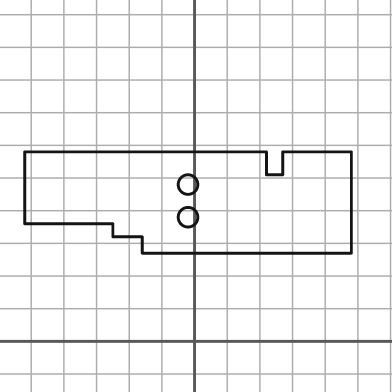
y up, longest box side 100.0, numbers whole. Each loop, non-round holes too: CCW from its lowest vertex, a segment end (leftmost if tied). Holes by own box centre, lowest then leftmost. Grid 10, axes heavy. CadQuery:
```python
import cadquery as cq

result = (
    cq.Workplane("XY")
    .moveTo(-16.0, 27.0)
    .lineTo(48.0, 27.0)
    .lineTo(48.0, 58.0)
    .lineTo(27.0, 58.0)
    .lineTo(27.0, 51.0)
    .lineTo(22.0, 51.0)
    .lineTo(22.0, 58.0)
    .lineTo(-52.0, 58.0)
    .lineTo(-52.0, 36.0)
    .lineTo(-25.0, 36.0)
    .lineTo(-25.0, 32.0)
    .lineTo(-16.0, 32.0)
    .close()
    .moveTo(-2.0, 38.0)
    .circle(3.0)
    .moveTo(-2.0, 48.0)
    .circle(3.0)
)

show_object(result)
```